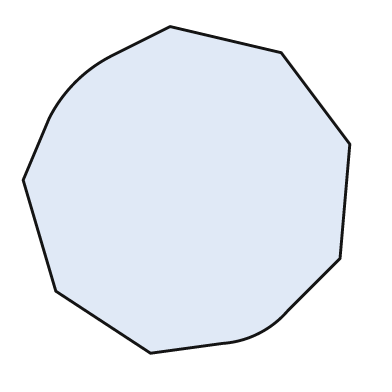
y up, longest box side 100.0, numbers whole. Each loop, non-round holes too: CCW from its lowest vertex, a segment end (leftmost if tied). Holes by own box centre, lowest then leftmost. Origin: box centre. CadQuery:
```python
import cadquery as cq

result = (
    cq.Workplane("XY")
    .moveTo(-11.0, -50.0)
    .lineTo(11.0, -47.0)
    .threePointArc((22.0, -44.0), (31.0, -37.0))
    .lineTo(47.0, -21.0)
    .lineTo(50.0, 14.0)
    .lineTo(29.0, 42.0)
    .lineTo(-5.0, 50.0)
    .lineTo(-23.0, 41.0)
    .threePointArc((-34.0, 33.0), (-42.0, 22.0))
    .lineTo(-50.0, 3.0)
    .lineTo(-40.0, -31.0)
    .close()
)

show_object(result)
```